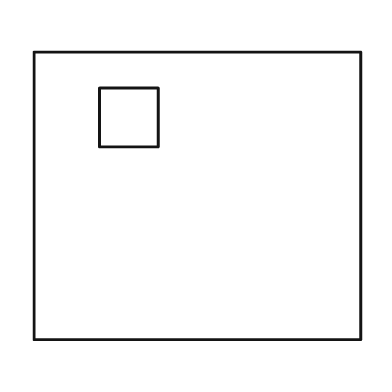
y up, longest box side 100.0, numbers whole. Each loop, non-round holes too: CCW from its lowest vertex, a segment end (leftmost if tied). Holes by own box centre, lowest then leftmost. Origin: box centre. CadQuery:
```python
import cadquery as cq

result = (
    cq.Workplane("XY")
    .moveTo(-50.0, -44.0)
    .lineTo(50.0, -44.0)
    .lineTo(50.0, 44.0)
    .lineTo(-50.0, 44.0)
    .close()
    .moveTo(-30.0, 15.0)
    .lineTo(-12.0, 15.0)
    .lineTo(-12.0, 33.0)
    .lineTo(-30.0, 33.0)
    .close()
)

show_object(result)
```